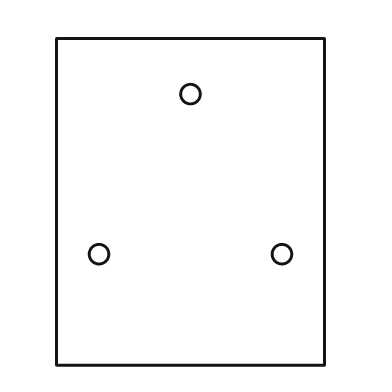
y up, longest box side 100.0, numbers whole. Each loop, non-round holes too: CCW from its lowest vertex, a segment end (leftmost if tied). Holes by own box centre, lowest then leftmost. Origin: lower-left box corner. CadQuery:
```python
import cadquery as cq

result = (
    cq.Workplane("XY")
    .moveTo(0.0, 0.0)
    .lineTo(82.0, 0.0)
    .lineTo(82.0, 100.0)
    .lineTo(0.0, 100.0)
    .close()
    .moveTo(13.0, 34.0)
    .circle(3.0)
    .moveTo(69.0, 34.0)
    .circle(3.0)
    .moveTo(41.0, 83.0)
    .circle(3.0)
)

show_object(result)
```